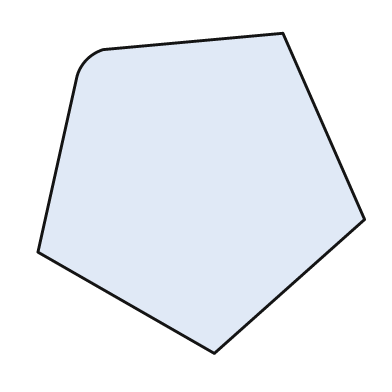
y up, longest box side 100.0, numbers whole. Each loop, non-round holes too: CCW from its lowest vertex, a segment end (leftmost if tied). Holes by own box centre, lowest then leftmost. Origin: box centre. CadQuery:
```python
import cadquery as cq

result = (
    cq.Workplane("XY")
    .moveTo(4.0, -49.0)
    .lineTo(50.0, -8.0)
    .lineTo(25.0, 49.0)
    .lineTo(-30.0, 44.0)
    .threePointArc((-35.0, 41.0), (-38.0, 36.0))
    .lineTo(-50.0, -18.0)
    .close()
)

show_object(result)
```